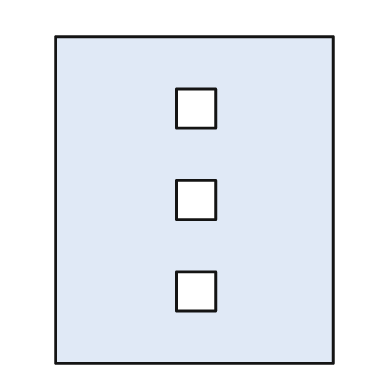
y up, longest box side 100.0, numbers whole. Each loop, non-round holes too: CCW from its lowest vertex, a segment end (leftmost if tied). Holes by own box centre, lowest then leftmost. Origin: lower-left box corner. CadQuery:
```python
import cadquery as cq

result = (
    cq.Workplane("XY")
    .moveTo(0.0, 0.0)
    .lineTo(85.0, 0.0)
    .lineTo(85.0, 100.0)
    .lineTo(0.0, 100.0)
    .close()
    .moveTo(37.0, 16.0)
    .lineTo(49.0, 16.0)
    .lineTo(49.0, 28.0)
    .lineTo(37.0, 28.0)
    .close()
    .moveTo(37.0, 44.0)
    .lineTo(49.0, 44.0)
    .lineTo(49.0, 56.0)
    .lineTo(37.0, 56.0)
    .close()
    .moveTo(37.0, 72.0)
    .lineTo(49.0, 72.0)
    .lineTo(49.0, 84.0)
    .lineTo(37.0, 84.0)
    .close()
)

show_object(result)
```